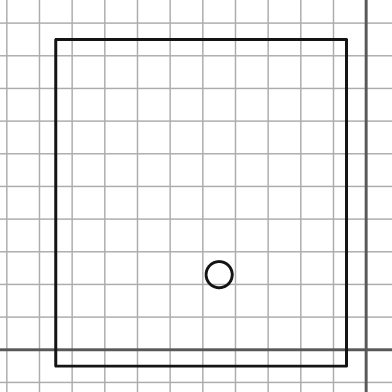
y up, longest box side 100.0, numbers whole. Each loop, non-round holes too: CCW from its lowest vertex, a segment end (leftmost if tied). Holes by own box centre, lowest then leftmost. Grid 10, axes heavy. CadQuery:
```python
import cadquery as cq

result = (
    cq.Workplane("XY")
    .moveTo(-95.0, -5.0)
    .lineTo(-6.0, -5.0)
    .lineTo(-6.0, 95.0)
    .lineTo(-95.0, 95.0)
    .close()
    .moveTo(-45.0, 23.0)
    .circle(4.0)
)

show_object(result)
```